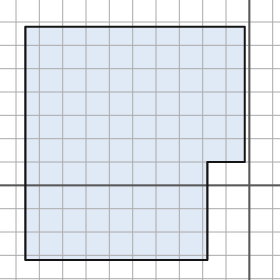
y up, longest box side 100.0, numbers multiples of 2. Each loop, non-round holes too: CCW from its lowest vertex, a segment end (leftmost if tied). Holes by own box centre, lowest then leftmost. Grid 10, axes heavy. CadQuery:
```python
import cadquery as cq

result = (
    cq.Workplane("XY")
    .moveTo(-96.0, -32.0)
    .lineTo(-18.0, -32.0)
    .lineTo(-18.0, 10.0)
    .lineTo(-2.0, 10.0)
    .lineTo(-2.0, 68.0)
    .lineTo(-96.0, 68.0)
    .close()
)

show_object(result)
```